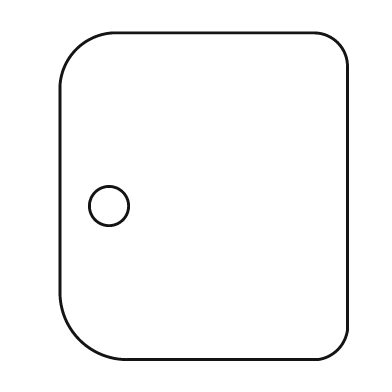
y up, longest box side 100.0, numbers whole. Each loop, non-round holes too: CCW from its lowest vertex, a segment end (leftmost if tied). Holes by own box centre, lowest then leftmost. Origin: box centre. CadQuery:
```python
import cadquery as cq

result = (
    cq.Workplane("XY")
    .moveTo(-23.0, -50.0)
    .lineTo(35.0, -50.0)
    .threePointArc((41.0, -47.0), (44.0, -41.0))
    .lineTo(44.0, 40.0)
    .threePointArc((41.0, 47.0), (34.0, 50.0))
    .lineTo(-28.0, 50.0)
    .threePointArc((-39.0, 45.0), (-44.0, 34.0))
    .lineTo(-44.0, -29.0)
    .threePointArc((-38.0, -44.0), (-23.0, -50.0))
    .close()
    .moveTo(-29.0, -3.0)
    .circle(6.0)
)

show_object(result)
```